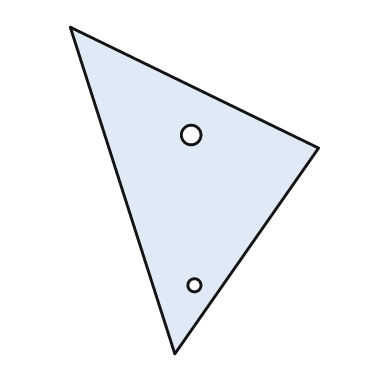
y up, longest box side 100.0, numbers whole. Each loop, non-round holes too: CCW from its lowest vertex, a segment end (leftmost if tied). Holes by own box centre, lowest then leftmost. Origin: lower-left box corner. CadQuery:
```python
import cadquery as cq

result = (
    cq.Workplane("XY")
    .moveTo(32.0, 0.0)
    .lineTo(76.0, 63.0)
    .lineTo(0.0, 100.0)
    .close()
    .moveTo(38.0, 21.0)
    .circle(2.0)
    .moveTo(37.0, 67.0)
    .circle(3.0)
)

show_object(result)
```